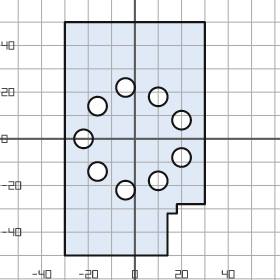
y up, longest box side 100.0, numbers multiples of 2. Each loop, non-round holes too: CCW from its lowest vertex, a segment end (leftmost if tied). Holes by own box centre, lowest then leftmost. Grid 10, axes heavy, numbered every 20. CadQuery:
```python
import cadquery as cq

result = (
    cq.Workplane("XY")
    .moveTo(-30.0, -50.0)
    .lineTo(14.0, -50.0)
    .lineTo(14.0, -32.0)
    .lineTo(18.0, -32.0)
    .lineTo(18.0, -28.0)
    .lineTo(30.0, -28.0)
    .lineTo(30.0, 50.0)
    .lineTo(-30.0, 50.0)
    .close()
    .moveTo(-4.0, -22.0)
    .circle(4.0)
    .moveTo(10.0, -18.0)
    .circle(4.0)
    .moveTo(-16.0, -14.0)
    .circle(4.0)
    .moveTo(20.0, -8.0)
    .circle(4.0)
    .moveTo(-22.0, 0.0)
    .circle(4.0)
    .moveTo(20.0, 8.0)
    .circle(4.0)
    .moveTo(-16.0, 14.0)
    .circle(4.0)
    .moveTo(10.0, 18.0)
    .circle(4.0)
    .moveTo(-4.0, 22.0)
    .circle(4.0)
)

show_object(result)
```